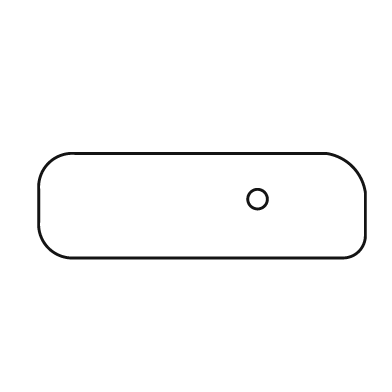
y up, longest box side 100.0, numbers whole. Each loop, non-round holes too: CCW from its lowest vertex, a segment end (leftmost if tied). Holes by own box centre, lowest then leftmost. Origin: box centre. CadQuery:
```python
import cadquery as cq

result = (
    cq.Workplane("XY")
    .moveTo(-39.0, -16.0)
    .lineTo(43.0, -16.0)
    .threePointArc((48.0, -14.0), (50.0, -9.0))
    .lineTo(50.0, 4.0)
    .threePointArc((46.0, 12.0), (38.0, 16.0))
    .lineTo(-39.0, 16.0)
    .threePointArc((-47.0, 13.0), (-50.0, 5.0))
    .lineTo(-50.0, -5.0)
    .threePointArc((-47.0, -13.0), (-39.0, -16.0))
    .close()
    .moveTo(17.0, 2.0)
    .circle(3.0)
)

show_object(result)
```